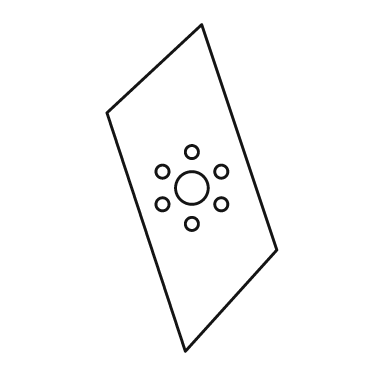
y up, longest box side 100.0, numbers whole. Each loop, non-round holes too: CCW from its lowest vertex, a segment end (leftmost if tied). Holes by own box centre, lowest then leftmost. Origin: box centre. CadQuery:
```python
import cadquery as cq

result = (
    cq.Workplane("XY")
    .moveTo(-2.0, -50.0)
    .lineTo(26.0, -19.0)
    .lineTo(3.0, 50.0)
    .lineTo(-26.0, 23.0)
    .close()
    .moveTo(0.0, -11.0)
    .circle(2.0)
    .moveTo(-9.0, -5.0)
    .circle(2.0)
    .moveTo(9.0, -5.0)
    .circle(2.0)
    .moveTo(0.0, 0.0)
    .circle(5.0)
    .moveTo(-9.0, 5.0)
    .circle(2.0)
    .moveTo(9.0, 5.0)
    .circle(2.0)
    .moveTo(0.0, 11.0)
    .circle(2.0)
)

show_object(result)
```